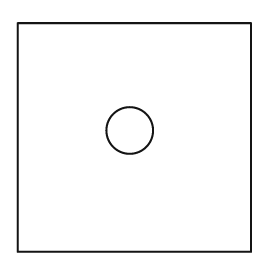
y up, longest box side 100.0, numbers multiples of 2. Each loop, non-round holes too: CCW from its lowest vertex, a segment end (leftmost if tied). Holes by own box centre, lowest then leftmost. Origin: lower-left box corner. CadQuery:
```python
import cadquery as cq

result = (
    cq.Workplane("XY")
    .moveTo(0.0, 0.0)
    .lineTo(100.0, 0.0)
    .lineTo(100.0, 98.0)
    .lineTo(0.0, 98.0)
    .close()
    .moveTo(48.0, 52.0)
    .circle(10.0)
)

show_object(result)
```